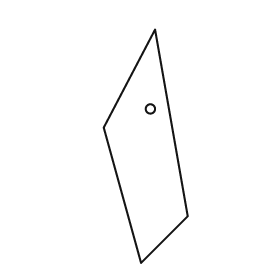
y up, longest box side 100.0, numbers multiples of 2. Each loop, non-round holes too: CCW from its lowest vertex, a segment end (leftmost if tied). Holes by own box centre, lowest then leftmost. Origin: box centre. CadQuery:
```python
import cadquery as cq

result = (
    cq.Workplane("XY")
    .moveTo(-2.0, -50.0)
    .lineTo(18.0, -30.0)
    .lineTo(4.0, 50.0)
    .lineTo(-18.0, 8.0)
    .close()
    .moveTo(2.0, 16.0)
    .circle(2.0)
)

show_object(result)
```